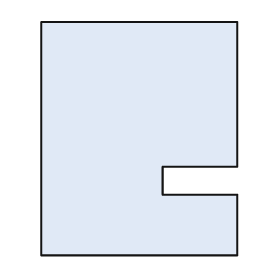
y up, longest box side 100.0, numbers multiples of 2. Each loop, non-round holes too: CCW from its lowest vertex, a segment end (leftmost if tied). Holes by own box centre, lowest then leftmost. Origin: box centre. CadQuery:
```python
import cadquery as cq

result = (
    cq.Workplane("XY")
    .moveTo(-42.0, -50.0)
    .lineTo(42.0, -50.0)
    .lineTo(42.0, -24.0)
    .lineTo(10.0, -24.0)
    .lineTo(10.0, -12.0)
    .lineTo(42.0, -12.0)
    .lineTo(42.0, 50.0)
    .lineTo(-42.0, 50.0)
    .close()
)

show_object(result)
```